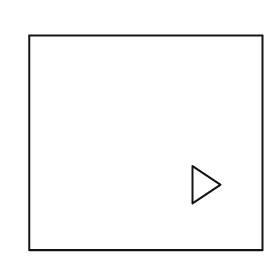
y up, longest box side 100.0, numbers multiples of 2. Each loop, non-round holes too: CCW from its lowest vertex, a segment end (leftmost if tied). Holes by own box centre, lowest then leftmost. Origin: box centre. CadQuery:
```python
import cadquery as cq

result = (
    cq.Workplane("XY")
    .moveTo(-50.0, -46.0)
    .lineTo(50.0, -46.0)
    .lineTo(50.0, 46.0)
    .lineTo(-50.0, 46.0)
    .close()
    .moveTo(20.0, -26.0)
    .lineTo(32.0, -18.0)
    .lineTo(20.0, -10.0)
    .close()
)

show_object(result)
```